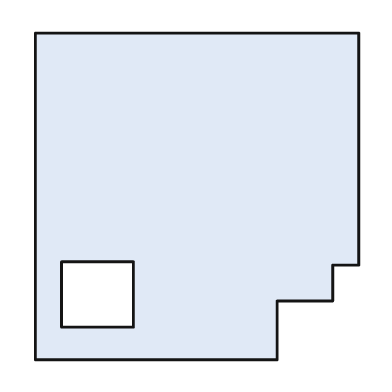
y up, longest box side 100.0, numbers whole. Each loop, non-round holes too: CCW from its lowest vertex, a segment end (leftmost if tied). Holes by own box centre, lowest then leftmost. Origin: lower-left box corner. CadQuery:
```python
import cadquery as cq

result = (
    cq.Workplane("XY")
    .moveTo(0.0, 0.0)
    .lineTo(74.0, 0.0)
    .lineTo(74.0, 18.0)
    .lineTo(91.0, 18.0)
    .lineTo(91.0, 29.0)
    .lineTo(99.0, 29.0)
    .lineTo(99.0, 100.0)
    .lineTo(0.0, 100.0)
    .close()
    .moveTo(8.0, 10.0)
    .lineTo(30.0, 10.0)
    .lineTo(30.0, 30.0)
    .lineTo(8.0, 30.0)
    .close()
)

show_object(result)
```